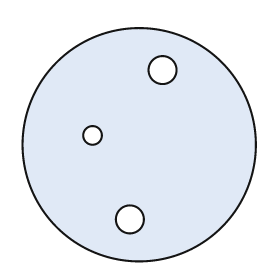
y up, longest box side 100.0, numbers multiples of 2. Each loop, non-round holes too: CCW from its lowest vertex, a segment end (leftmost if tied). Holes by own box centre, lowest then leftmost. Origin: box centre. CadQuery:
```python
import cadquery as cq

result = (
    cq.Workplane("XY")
    .moveTo(0.0, 0.0)
    .circle(50.0)
    .moveTo(-4.0, -32.0)
    .circle(6.0)
    .moveTo(-20.0, 4.0)
    .circle(4.0)
    .moveTo(10.0, 32.0)
    .circle(6.0)
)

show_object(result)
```